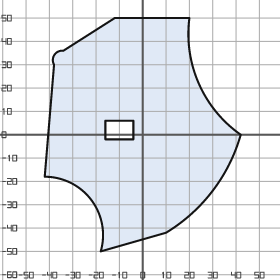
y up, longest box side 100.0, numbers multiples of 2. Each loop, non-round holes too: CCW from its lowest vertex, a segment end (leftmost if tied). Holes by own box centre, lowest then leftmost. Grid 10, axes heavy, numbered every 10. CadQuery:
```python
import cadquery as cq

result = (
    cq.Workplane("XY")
    .moveTo(-18.0, -50.0)
    .lineTo(10.0, -42.0)
    .threePointArc((30.0, -24.0), (42.0, 0.0))
    .threePointArc((24.0, 22.0), (20.0, 50.0))
    .lineTo(-12.0, 50.0)
    .lineTo(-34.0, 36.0)
    .threePointArc((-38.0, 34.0), (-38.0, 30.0))
    .lineTo(-42.0, -18.0)
    .threePointArc((-22.0, -28.0), (-18.0, -50.0))
    .close()
    .moveTo(-16.0, -2.0)
    .lineTo(-4.0, -2.0)
    .lineTo(-4.0, 6.0)
    .lineTo(-16.0, 6.0)
    .close()
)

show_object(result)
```